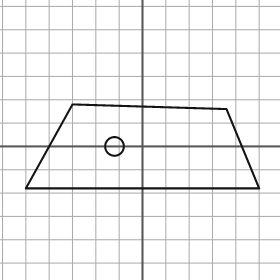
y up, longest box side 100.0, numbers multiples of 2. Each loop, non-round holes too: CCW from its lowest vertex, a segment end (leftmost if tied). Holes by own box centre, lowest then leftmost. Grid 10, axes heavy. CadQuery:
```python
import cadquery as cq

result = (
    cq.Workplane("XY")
    .moveTo(-50.0, -18.0)
    .lineTo(50.0, -18.0)
    .lineTo(36.0, 16.0)
    .lineTo(-30.0, 18.0)
    .close()
    .moveTo(-12.0, 0.0)
    .circle(4.0)
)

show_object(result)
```